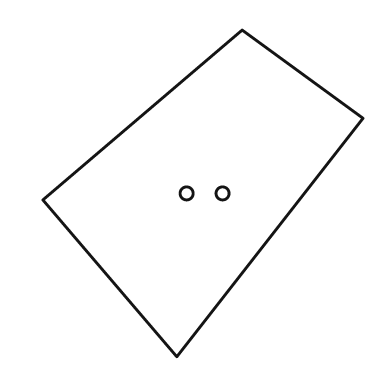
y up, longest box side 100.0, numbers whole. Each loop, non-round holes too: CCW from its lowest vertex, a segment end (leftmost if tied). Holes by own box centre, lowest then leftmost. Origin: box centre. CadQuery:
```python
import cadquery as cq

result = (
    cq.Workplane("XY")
    .moveTo(-8.0, -50.0)
    .lineTo(49.0, 23.0)
    .lineTo(12.0, 50.0)
    .lineTo(-49.0, -2.0)
    .close()
    .moveTo(-5.0, 0.0)
    .circle(2.0)
    .moveTo(6.0, 0.0)
    .circle(2.0)
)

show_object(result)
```